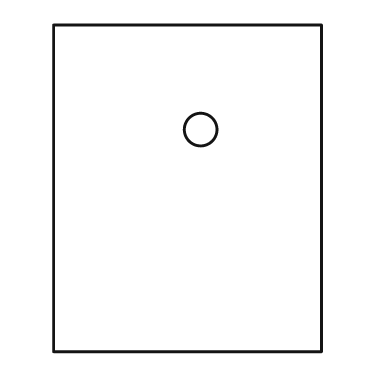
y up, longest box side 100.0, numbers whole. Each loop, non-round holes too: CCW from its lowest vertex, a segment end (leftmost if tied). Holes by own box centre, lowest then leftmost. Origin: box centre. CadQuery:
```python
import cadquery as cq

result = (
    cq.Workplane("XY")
    .moveTo(-41.0, -50.0)
    .lineTo(41.0, -50.0)
    .lineTo(41.0, 50.0)
    .lineTo(-41.0, 50.0)
    .close()
    .moveTo(4.0, 18.0)
    .circle(5.0)
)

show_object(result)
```